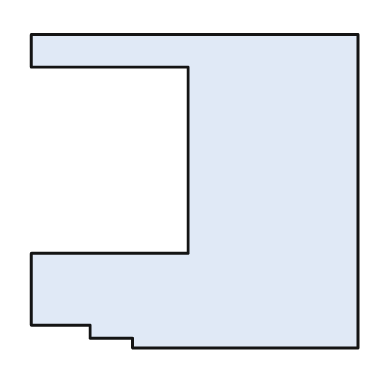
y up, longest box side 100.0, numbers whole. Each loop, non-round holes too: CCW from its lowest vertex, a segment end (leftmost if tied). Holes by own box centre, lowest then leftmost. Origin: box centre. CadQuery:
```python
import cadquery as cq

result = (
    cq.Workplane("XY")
    .moveTo(-19.0, -48.0)
    .lineTo(50.0, -48.0)
    .lineTo(50.0, 48.0)
    .lineTo(-50.0, 48.0)
    .lineTo(-50.0, 38.0)
    .lineTo(-2.0, 38.0)
    .lineTo(-2.0, -19.0)
    .lineTo(-50.0, -19.0)
    .lineTo(-50.0, -41.0)
    .lineTo(-32.0, -41.0)
    .lineTo(-32.0, -45.0)
    .lineTo(-19.0, -45.0)
    .close()
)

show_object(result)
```